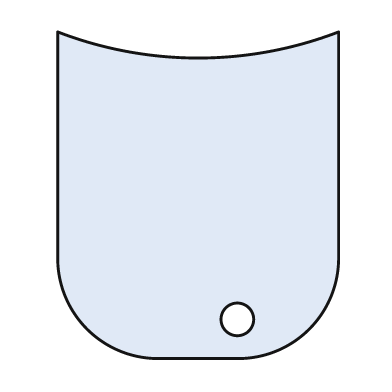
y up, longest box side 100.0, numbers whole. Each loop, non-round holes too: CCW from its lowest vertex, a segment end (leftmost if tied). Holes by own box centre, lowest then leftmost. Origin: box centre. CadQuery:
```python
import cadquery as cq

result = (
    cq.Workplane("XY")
    .moveTo(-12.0, -50.0)
    .lineTo(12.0, -50.0)
    .threePointArc((34.0, -41.0), (43.0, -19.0))
    .lineTo(43.0, 50.0)
    .threePointArc((0.0, 42.0), (-43.0, 50.0))
    .lineTo(-43.0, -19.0)
    .threePointArc((-34.0, -41.0), (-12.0, -50.0))
    .close()
    .moveTo(12.0, -38.0)
    .circle(5.0)
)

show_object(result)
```